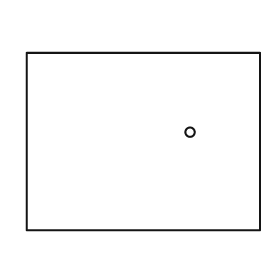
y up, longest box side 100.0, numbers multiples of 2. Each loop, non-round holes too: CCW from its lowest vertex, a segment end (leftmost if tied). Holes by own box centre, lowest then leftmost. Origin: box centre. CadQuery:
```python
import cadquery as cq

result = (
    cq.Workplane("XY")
    .moveTo(-50.0, -38.0)
    .lineTo(50.0, -38.0)
    .lineTo(50.0, 38.0)
    .lineTo(-50.0, 38.0)
    .close()
    .moveTo(20.0, 4.0)
    .circle(2.0)
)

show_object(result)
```